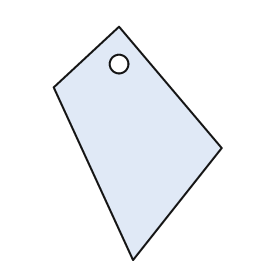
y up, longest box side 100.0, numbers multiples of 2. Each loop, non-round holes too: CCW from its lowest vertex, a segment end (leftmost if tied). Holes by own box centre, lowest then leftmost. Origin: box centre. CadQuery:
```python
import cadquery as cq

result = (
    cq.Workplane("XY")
    .moveTo(-2.0, -50.0)
    .lineTo(36.0, -2.0)
    .lineTo(-8.0, 50.0)
    .lineTo(-36.0, 24.0)
    .close()
    .moveTo(-8.0, 34.0)
    .circle(4.0)
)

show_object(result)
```